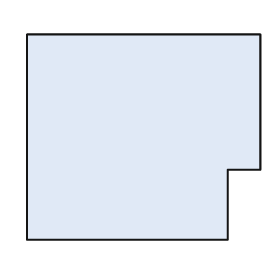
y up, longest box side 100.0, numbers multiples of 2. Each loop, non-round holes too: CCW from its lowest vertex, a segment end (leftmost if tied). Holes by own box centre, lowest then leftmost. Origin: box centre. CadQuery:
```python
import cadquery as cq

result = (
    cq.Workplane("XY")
    .moveTo(-50.0, -44.0)
    .lineTo(36.0, -44.0)
    .lineTo(36.0, -14.0)
    .lineTo(50.0, -14.0)
    .lineTo(50.0, 44.0)
    .lineTo(-50.0, 44.0)
    .close()
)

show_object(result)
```